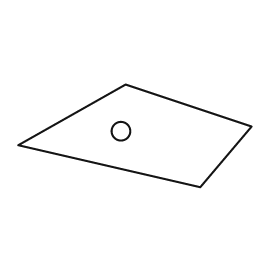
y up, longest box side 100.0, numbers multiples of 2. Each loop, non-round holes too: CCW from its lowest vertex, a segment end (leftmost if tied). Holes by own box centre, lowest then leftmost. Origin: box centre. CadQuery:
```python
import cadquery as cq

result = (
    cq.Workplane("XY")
    .moveTo(28.0, -22.0)
    .lineTo(50.0, 4.0)
    .lineTo(-4.0, 22.0)
    .lineTo(-50.0, -4.0)
    .close()
    .moveTo(-6.0, 2.0)
    .circle(4.0)
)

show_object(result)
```